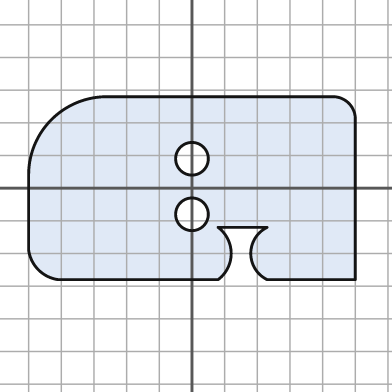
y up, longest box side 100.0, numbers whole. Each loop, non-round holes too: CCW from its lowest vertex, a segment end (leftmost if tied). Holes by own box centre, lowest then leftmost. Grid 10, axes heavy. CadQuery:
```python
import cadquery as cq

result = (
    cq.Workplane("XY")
    .moveTo(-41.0, -28.0)
    .lineTo(8.0, -28.0)
    .threePointArc((12.0, -20.0), (8.0, -12.0))
    .lineTo(23.0, -12.0)
    .threePointArc((18.0, -20.0), (23.0, -28.0))
    .lineTo(50.0, -28.0)
    .lineTo(50.0, 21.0)
    .threePointArc((48.0, 26.0), (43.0, 28.0))
    .lineTo(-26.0, 28.0)
    .threePointArc((-43.0, 21.0), (-50.0, 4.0))
    .lineTo(-50.0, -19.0)
    .threePointArc((-47.0, -25.0), (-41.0, -28.0))
    .close()
    .moveTo(0.0, -8.0)
    .circle(5.0)
    .moveTo(0.0, 9.0)
    .circle(5.0)
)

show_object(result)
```